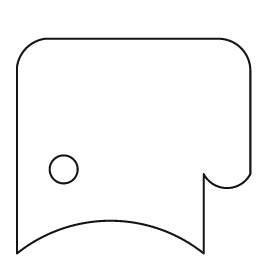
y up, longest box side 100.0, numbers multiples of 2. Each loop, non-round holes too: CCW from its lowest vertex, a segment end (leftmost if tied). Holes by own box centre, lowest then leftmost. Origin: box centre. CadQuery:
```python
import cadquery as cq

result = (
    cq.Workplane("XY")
    .moveTo(-50.0, -46.0)
    .threePointArc((-10.0, -32.0), (30.0, -46.0))
    .lineTo(30.0, -12.0)
    .threePointArc((40.0, -18.0), (50.0, -12.0))
    .lineTo(50.0, 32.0)
    .threePointArc((46.0, 42.0), (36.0, 46.0))
    .lineTo(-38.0, 46.0)
    .threePointArc((-46.0, 42.0), (-50.0, 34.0))
    .close()
    .moveTo(-30.0, -10.0)
    .circle(6.0)
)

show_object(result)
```